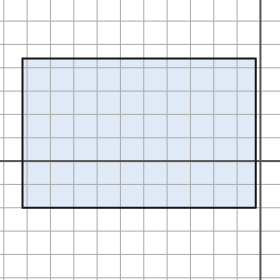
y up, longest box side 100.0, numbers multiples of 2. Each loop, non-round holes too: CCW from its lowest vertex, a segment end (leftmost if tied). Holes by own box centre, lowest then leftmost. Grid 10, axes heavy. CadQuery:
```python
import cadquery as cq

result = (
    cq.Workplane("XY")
    .moveTo(-102.0, -20.0)
    .lineTo(-2.0, -20.0)
    .lineTo(-2.0, 44.0)
    .lineTo(-102.0, 44.0)
    .close()
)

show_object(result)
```